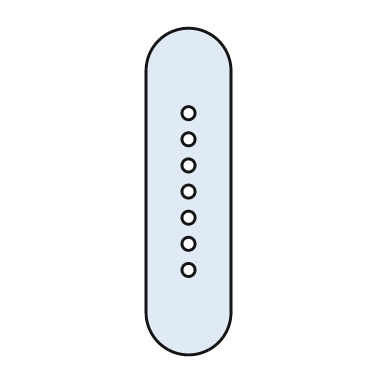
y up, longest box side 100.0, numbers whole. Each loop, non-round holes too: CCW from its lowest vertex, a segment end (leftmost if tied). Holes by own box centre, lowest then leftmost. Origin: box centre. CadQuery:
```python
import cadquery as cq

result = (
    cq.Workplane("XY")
    .moveTo(-13.0, -37.0)
    .threePointArc((0.0, -50.0), (13.0, -37.0))
    .lineTo(13.0, 37.0)
    .threePointArc((0.0, 50.0), (-13.0, 37.0))
    .close()
    .moveTo(0.0, -24.0)
    .circle(2.0)
    .moveTo(0.0, -16.0)
    .circle(2.0)
    .moveTo(0.0, -8.0)
    .circle(2.0)
    .moveTo(0.0, 0.0)
    .circle(2.0)
    .moveTo(0.0, 8.0)
    .circle(2.0)
    .moveTo(0.0, 16.0)
    .circle(2.0)
    .moveTo(0.0, 24.0)
    .circle(2.0)
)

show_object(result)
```